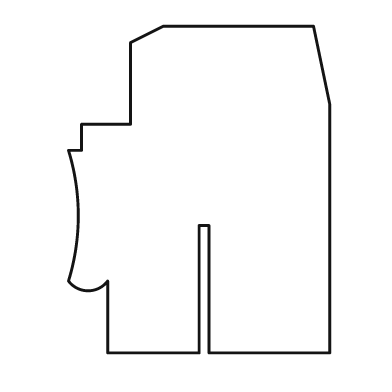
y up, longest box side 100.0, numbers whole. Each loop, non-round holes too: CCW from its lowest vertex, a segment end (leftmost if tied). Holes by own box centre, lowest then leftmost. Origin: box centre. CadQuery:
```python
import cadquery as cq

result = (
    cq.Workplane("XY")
    .moveTo(-28.0, -50.0)
    .lineTo(0.0, -50.0)
    .lineTo(0.0, -11.0)
    .lineTo(3.0, -11.0)
    .lineTo(3.0, -50.0)
    .lineTo(40.0, -50.0)
    .lineTo(40.0, 26.0)
    .lineTo(35.0, 50.0)
    .lineTo(-11.0, 50.0)
    .lineTo(-21.0, 45.0)
    .lineTo(-21.0, 20.0)
    .lineTo(-36.0, 20.0)
    .lineTo(-36.0, 12.0)
    .lineTo(-40.0, 12.0)
    .threePointArc((-37.0, -8.0), (-40.0, -28.0))
    .threePointArc((-34.0, -31.0), (-28.0, -28.0))
    .close()
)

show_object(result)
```